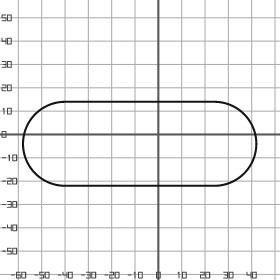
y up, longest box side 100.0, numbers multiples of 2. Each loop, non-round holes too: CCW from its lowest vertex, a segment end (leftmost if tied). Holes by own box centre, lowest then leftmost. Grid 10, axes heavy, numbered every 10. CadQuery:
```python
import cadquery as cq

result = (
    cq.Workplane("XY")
    .moveTo(-40.0, -22.0)
    .lineTo(24.0, -22.0)
    .threePointArc((42.0, -4.0), (24.0, 14.0))
    .lineTo(-40.0, 14.0)
    .threePointArc((-58.0, -4.0), (-40.0, -22.0))
    .close()
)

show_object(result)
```